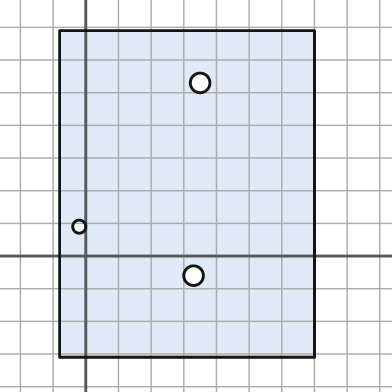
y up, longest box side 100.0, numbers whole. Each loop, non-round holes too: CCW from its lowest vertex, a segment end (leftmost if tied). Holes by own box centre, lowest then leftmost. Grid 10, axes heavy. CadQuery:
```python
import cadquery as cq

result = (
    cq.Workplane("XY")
    .moveTo(-8.0, -31.0)
    .lineTo(70.0, -31.0)
    .lineTo(70.0, 69.0)
    .lineTo(-8.0, 69.0)
    .close()
    .moveTo(33.0, -6.0)
    .circle(3.0)
    .moveTo(-2.0, 9.0)
    .circle(2.0)
    .moveTo(35.0, 53.0)
    .circle(3.0)
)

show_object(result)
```